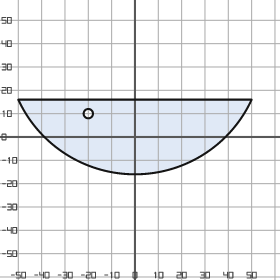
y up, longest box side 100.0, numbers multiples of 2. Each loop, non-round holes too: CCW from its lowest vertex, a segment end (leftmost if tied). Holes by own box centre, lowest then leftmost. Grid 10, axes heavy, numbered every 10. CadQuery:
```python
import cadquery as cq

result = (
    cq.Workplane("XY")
    .moveTo(-50.0, 16.0)
    .threePointArc((0.0, -16.0), (50.0, 16.0))
    .close()
    .moveTo(-20.0, 10.0)
    .circle(2.0)
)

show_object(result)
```